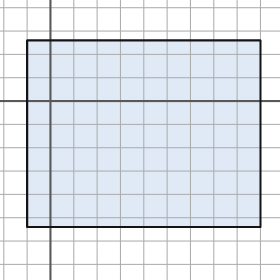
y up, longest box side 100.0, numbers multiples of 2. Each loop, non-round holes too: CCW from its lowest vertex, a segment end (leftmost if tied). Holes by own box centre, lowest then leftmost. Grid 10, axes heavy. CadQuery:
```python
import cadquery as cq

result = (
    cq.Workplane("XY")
    .moveTo(-10.0, -54.0)
    .lineTo(90.0, -54.0)
    .lineTo(90.0, 26.0)
    .lineTo(-10.0, 26.0)
    .close()
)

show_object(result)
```